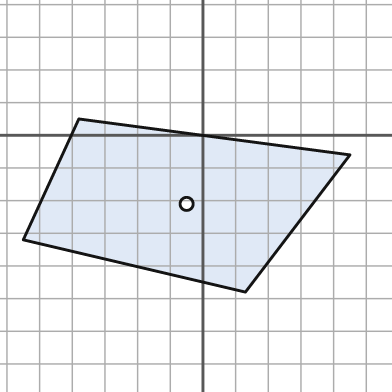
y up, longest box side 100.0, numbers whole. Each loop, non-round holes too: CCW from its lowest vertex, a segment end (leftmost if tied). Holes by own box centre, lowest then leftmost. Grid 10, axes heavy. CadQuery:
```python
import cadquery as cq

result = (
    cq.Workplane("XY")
    .moveTo(13.0, -48.0)
    .lineTo(45.0, -6.0)
    .lineTo(-38.0, 5.0)
    .lineTo(-55.0, -32.0)
    .close()
    .moveTo(-5.0, -21.0)
    .circle(2.0)
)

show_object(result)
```